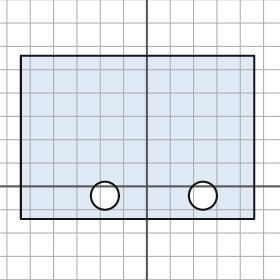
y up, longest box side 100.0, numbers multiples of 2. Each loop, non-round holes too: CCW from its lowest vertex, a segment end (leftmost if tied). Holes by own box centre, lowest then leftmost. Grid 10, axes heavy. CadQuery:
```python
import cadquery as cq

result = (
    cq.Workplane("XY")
    .moveTo(-54.0, -14.0)
    .lineTo(46.0, -14.0)
    .lineTo(46.0, 56.0)
    .lineTo(-54.0, 56.0)
    .close()
    .moveTo(-18.0, -4.0)
    .circle(6.0)
    .moveTo(24.0, -4.0)
    .circle(6.0)
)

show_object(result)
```